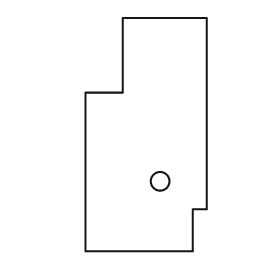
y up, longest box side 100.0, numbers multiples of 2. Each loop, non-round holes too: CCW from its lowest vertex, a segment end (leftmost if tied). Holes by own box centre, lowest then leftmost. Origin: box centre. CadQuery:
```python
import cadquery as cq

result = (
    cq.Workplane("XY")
    .moveTo(-26.0, -50.0)
    .lineTo(20.0, -50.0)
    .lineTo(20.0, -32.0)
    .lineTo(26.0, -32.0)
    .lineTo(26.0, 50.0)
    .lineTo(-10.0, 50.0)
    .lineTo(-10.0, 18.0)
    .lineTo(-26.0, 18.0)
    .close()
    .moveTo(6.0, -20.0)
    .circle(4.0)
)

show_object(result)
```